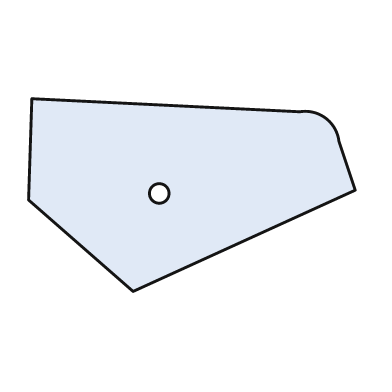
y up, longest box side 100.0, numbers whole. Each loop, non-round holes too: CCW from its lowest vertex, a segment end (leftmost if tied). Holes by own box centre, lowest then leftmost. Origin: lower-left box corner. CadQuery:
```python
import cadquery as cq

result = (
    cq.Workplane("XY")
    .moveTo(32.0, 0.0)
    .lineTo(100.0, 31.0)
    .lineTo(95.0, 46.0)
    .threePointArc((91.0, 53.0), (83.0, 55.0))
    .lineTo(1.0, 59.0)
    .lineTo(0.0, 28.0)
    .close()
    .moveTo(40.0, 30.0)
    .circle(3.0)
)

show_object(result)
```